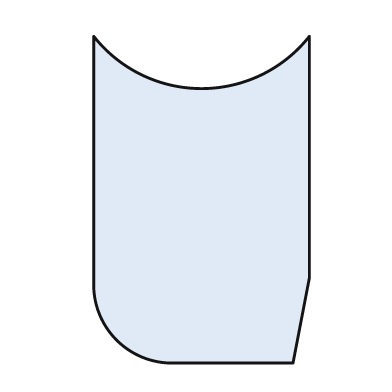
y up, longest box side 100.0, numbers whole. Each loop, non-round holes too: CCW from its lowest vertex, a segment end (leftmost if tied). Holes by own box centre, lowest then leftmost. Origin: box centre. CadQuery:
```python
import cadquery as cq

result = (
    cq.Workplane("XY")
    .moveTo(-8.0, -50.0)
    .lineTo(28.0, -50.0)
    .lineTo(33.0, -24.0)
    .lineTo(33.0, 50.0)
    .threePointArc((0.0, 34.0), (-33.0, 50.0))
    .lineTo(-33.0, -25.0)
    .threePointArc((-26.0, -43.0), (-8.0, -50.0))
    .close()
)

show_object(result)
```